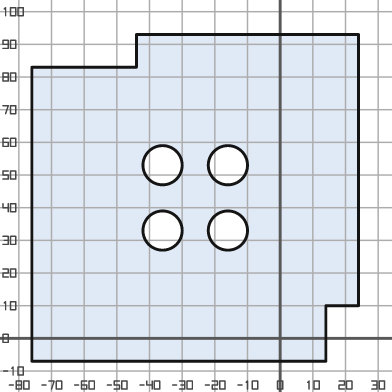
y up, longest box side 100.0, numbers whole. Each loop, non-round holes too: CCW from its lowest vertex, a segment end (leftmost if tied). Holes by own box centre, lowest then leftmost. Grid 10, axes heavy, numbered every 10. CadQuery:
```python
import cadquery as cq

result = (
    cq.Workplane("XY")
    .moveTo(-76.0, -7.0)
    .lineTo(14.0, -7.0)
    .lineTo(14.0, 10.0)
    .lineTo(24.0, 10.0)
    .lineTo(24.0, 93.0)
    .lineTo(-44.0, 93.0)
    .lineTo(-44.0, 83.0)
    .lineTo(-76.0, 83.0)
    .close()
    .moveTo(-36.0, 33.0)
    .circle(6.0)
    .moveTo(-16.0, 33.0)
    .circle(6.0)
    .moveTo(-36.0, 53.0)
    .circle(6.0)
    .moveTo(-16.0, 53.0)
    .circle(6.0)
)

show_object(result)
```